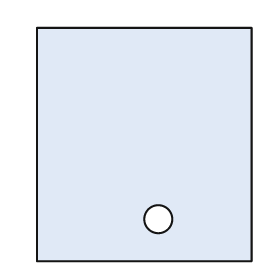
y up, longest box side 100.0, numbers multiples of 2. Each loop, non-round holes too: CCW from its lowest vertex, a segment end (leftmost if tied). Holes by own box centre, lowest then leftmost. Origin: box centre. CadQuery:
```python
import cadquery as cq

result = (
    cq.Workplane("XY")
    .moveTo(-46.0, -50.0)
    .lineTo(46.0, -50.0)
    .lineTo(46.0, 50.0)
    .lineTo(-46.0, 50.0)
    .close()
    .moveTo(6.0, -32.0)
    .circle(6.0)
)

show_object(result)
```